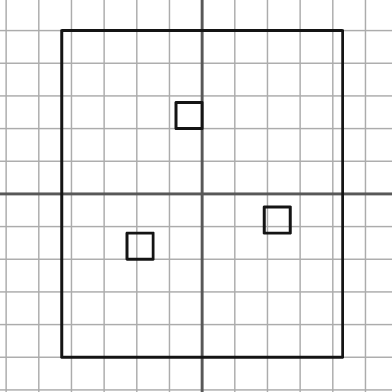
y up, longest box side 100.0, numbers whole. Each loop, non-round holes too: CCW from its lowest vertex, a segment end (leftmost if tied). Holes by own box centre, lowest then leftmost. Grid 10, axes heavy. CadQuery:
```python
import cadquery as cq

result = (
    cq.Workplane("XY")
    .moveTo(-43.0, -50.0)
    .lineTo(43.0, -50.0)
    .lineTo(43.0, 50.0)
    .lineTo(-43.0, 50.0)
    .close()
    .moveTo(-23.0, -20.0)
    .lineTo(-15.0, -20.0)
    .lineTo(-15.0, -12.0)
    .lineTo(-23.0, -12.0)
    .close()
    .moveTo(19.0, -12.0)
    .lineTo(27.0, -12.0)
    .lineTo(27.0, -4.0)
    .lineTo(19.0, -4.0)
    .close()
    .moveTo(-8.0, 20.0)
    .lineTo(0.0, 20.0)
    .lineTo(0.0, 28.0)
    .lineTo(-8.0, 28.0)
    .close()
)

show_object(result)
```